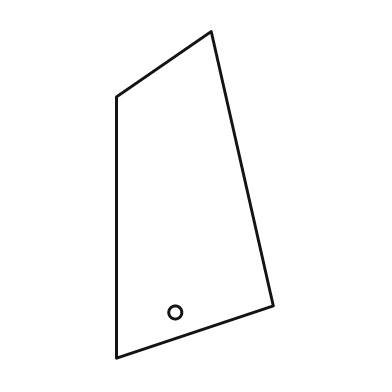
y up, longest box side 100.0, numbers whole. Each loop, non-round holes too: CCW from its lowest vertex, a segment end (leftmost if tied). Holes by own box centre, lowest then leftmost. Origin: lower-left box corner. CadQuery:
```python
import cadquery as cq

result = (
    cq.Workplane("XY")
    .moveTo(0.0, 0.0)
    .lineTo(48.0, 16.0)
    .lineTo(29.0, 100.0)
    .lineTo(0.0, 80.0)
    .close()
    .moveTo(18.0, 14.0)
    .circle(2.0)
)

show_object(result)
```